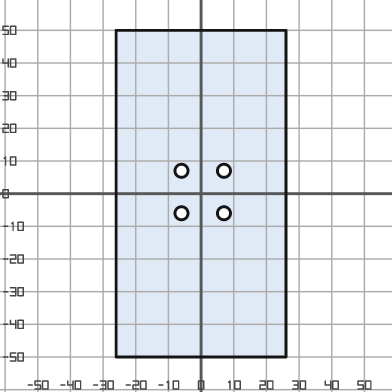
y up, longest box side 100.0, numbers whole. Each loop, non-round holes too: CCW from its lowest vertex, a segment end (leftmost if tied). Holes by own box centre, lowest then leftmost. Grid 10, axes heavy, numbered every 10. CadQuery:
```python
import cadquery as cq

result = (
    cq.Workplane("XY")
    .moveTo(-26.0, -50.0)
    .lineTo(26.0, -50.0)
    .lineTo(26.0, 50.0)
    .lineTo(-26.0, 50.0)
    .close()
    .moveTo(-6.0, -6.0)
    .circle(2.0)
    .moveTo(7.0, -6.0)
    .circle(2.0)
    .moveTo(-6.0, 7.0)
    .circle(2.0)
    .moveTo(7.0, 7.0)
    .circle(2.0)
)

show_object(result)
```